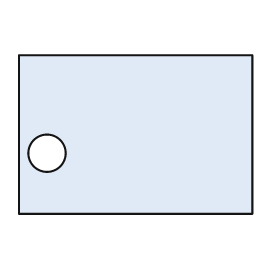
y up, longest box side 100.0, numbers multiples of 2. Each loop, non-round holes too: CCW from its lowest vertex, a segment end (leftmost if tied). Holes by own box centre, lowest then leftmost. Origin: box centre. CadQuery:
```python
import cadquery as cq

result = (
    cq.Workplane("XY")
    .moveTo(-50.0, -34.0)
    .lineTo(50.0, -34.0)
    .lineTo(50.0, 34.0)
    .lineTo(-50.0, 34.0)
    .close()
    .moveTo(-38.0, -8.0)
    .circle(8.0)
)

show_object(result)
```